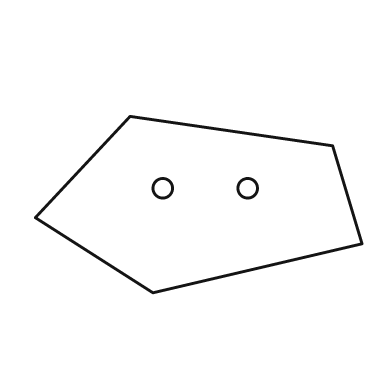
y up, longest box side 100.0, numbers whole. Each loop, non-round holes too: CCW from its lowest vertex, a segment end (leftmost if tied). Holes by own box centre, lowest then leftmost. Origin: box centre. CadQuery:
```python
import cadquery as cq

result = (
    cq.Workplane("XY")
    .moveTo(-14.0, -27.0)
    .lineTo(50.0, -12.0)
    .lineTo(41.0, 18.0)
    .lineTo(-21.0, 27.0)
    .lineTo(-50.0, -4.0)
    .close()
    .moveTo(-11.0, 5.0)
    .circle(3.0)
    .moveTo(15.0, 5.0)
    .circle(3.0)
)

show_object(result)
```